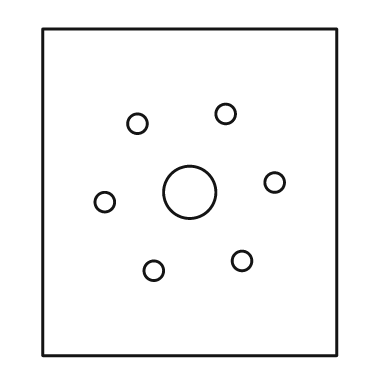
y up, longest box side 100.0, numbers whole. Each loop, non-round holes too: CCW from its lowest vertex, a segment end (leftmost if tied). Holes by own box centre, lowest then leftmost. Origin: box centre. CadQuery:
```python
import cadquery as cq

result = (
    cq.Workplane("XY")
    .moveTo(-45.0, -50.0)
    .lineTo(45.0, -50.0)
    .lineTo(45.0, 50.0)
    .lineTo(-45.0, 50.0)
    .close()
    .moveTo(-11.0, -24.0)
    .circle(3.0)
    .moveTo(16.0, -21.0)
    .circle(3.0)
    .moveTo(-26.0, -3.0)
    .circle(3.0)
    .moveTo(0.0, 0.0)
    .circle(8.0)
    .moveTo(26.0, 3.0)
    .circle(3.0)
    .moveTo(-16.0, 21.0)
    .circle(3.0)
    .moveTo(11.0, 24.0)
    .circle(3.0)
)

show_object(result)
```